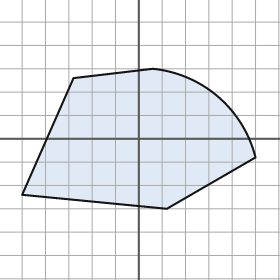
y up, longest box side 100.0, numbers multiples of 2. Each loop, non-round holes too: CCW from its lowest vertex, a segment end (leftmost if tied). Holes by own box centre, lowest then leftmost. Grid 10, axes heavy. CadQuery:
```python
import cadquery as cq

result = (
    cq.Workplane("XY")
    .moveTo(12.0, -30.0)
    .lineTo(50.0, -8.0)
    .threePointArc((34.0, 18.0), (6.0, 30.0))
    .lineTo(-28.0, 26.0)
    .lineTo(-50.0, -24.0)
    .close()
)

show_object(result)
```